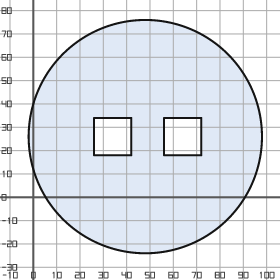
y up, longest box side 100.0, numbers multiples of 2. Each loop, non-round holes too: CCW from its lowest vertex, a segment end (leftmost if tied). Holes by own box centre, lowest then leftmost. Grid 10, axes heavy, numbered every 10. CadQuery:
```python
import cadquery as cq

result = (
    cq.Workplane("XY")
    .moveTo(48.0, 26.0)
    .circle(50.0)
    .moveTo(26.0, 18.0)
    .lineTo(42.0, 18.0)
    .lineTo(42.0, 34.0)
    .lineTo(26.0, 34.0)
    .close()
    .moveTo(56.0, 18.0)
    .lineTo(72.0, 18.0)
    .lineTo(72.0, 34.0)
    .lineTo(56.0, 34.0)
    .close()
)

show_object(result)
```